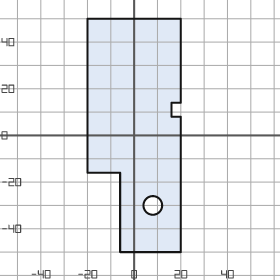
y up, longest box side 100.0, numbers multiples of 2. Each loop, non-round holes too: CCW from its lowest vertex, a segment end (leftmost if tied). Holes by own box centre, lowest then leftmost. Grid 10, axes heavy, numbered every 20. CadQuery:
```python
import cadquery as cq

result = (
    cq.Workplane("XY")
    .moveTo(-6.0, -50.0)
    .lineTo(20.0, -50.0)
    .lineTo(20.0, 8.0)
    .lineTo(16.0, 8.0)
    .lineTo(16.0, 14.0)
    .lineTo(20.0, 14.0)
    .lineTo(20.0, 50.0)
    .lineTo(-20.0, 50.0)
    .lineTo(-20.0, -16.0)
    .lineTo(-6.0, -16.0)
    .close()
    .moveTo(8.0, -30.0)
    .circle(4.0)
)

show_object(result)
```